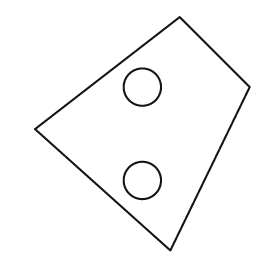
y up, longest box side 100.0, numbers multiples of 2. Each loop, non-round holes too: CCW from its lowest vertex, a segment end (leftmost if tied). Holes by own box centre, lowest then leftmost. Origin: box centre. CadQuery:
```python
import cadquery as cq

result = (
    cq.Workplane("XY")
    .moveTo(12.0, -50.0)
    .lineTo(46.0, 20.0)
    .lineTo(16.0, 50.0)
    .lineTo(-46.0, 2.0)
    .close()
    .moveTo(0.0, -20.0)
    .circle(8.0)
    .moveTo(0.0, 20.0)
    .circle(8.0)
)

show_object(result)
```